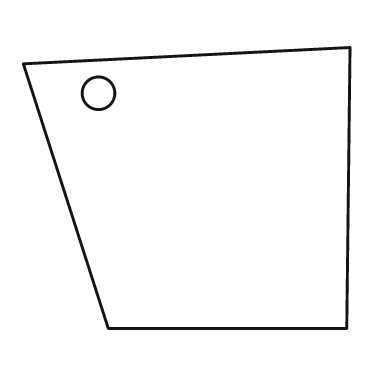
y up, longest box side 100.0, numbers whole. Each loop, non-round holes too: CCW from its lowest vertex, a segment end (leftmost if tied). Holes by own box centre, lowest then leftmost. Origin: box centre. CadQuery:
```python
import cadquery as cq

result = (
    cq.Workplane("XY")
    .moveTo(-24.0, -43.0)
    .lineTo(49.0, -43.0)
    .lineTo(50.0, 43.0)
    .lineTo(-50.0, 38.0)
    .close()
    .moveTo(-27.0, 29.0)
    .circle(5.0)
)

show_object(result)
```